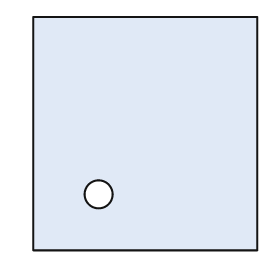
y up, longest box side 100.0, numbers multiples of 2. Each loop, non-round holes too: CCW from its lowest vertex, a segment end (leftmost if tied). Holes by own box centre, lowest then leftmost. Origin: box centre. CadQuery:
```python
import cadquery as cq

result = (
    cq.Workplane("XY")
    .moveTo(-48.0, -50.0)
    .lineTo(48.0, -50.0)
    .lineTo(48.0, 50.0)
    .lineTo(-48.0, 50.0)
    .close()
    .moveTo(-20.0, -26.0)
    .circle(6.0)
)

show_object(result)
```